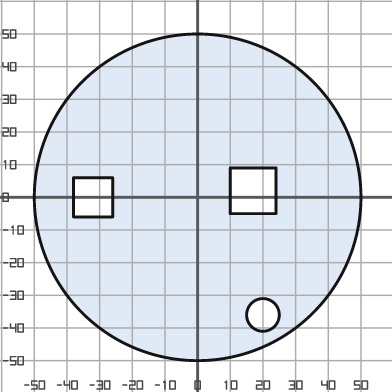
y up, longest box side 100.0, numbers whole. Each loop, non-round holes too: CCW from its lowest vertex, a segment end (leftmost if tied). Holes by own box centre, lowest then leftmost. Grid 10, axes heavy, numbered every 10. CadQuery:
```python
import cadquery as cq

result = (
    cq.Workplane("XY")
    .moveTo(0.0, 0.0)
    .circle(50.0)
    .moveTo(20.0, -36.0)
    .circle(5.0)
    .moveTo(-38.0, -6.0)
    .lineTo(-26.0, -6.0)
    .lineTo(-26.0, 6.0)
    .lineTo(-38.0, 6.0)
    .close()
    .moveTo(10.0, -5.0)
    .lineTo(24.0, -5.0)
    .lineTo(24.0, 9.0)
    .lineTo(10.0, 9.0)
    .close()
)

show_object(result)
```